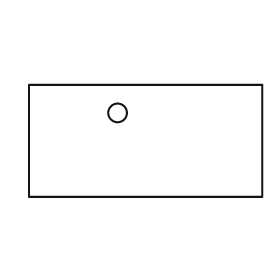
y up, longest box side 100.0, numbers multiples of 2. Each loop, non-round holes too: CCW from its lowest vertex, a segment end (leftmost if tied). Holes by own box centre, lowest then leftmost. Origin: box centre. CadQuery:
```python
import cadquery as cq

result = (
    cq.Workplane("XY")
    .moveTo(-50.0, -24.0)
    .lineTo(50.0, -24.0)
    .lineTo(50.0, 24.0)
    .lineTo(-50.0, 24.0)
    .close()
    .moveTo(-12.0, 12.0)
    .circle(4.0)
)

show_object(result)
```